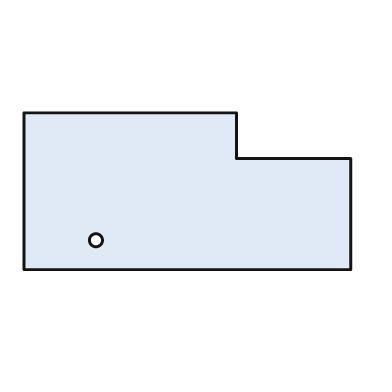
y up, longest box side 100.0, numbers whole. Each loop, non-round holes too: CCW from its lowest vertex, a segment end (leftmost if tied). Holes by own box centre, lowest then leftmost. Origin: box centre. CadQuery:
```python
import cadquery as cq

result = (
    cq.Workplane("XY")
    .moveTo(-50.0, -24.0)
    .lineTo(50.0, -24.0)
    .lineTo(50.0, 10.0)
    .lineTo(15.0, 10.0)
    .lineTo(15.0, 24.0)
    .lineTo(-50.0, 24.0)
    .close()
    .moveTo(-28.0, -15.0)
    .circle(2.0)
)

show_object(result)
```